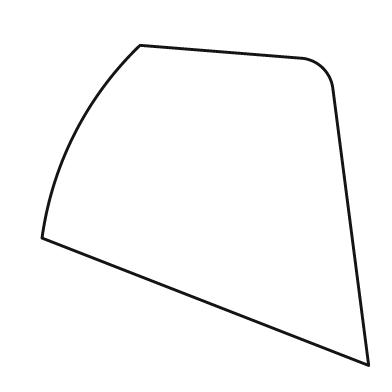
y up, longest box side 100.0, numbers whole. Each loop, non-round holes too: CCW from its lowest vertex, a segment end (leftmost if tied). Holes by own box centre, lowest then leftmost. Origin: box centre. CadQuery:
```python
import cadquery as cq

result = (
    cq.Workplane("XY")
    .moveTo(50.0, -49.0)
    .lineTo(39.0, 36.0)
    .threePointArc((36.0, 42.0), (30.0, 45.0))
    .lineTo(-20.0, 49.0)
    .threePointArc((-40.0, 22.0), (-50.0, -10.0))
    .close()
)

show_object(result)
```